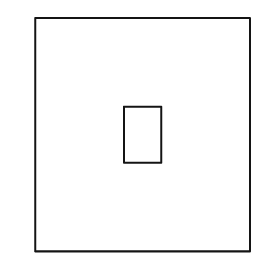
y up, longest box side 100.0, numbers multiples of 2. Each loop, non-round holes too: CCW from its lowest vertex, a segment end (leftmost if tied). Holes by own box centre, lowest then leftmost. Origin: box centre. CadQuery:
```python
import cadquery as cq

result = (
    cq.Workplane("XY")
    .moveTo(-46.0, -50.0)
    .lineTo(46.0, -50.0)
    .lineTo(46.0, 50.0)
    .lineTo(-46.0, 50.0)
    .close()
    .moveTo(-8.0, -12.0)
    .lineTo(8.0, -12.0)
    .lineTo(8.0, 12.0)
    .lineTo(-8.0, 12.0)
    .close()
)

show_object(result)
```